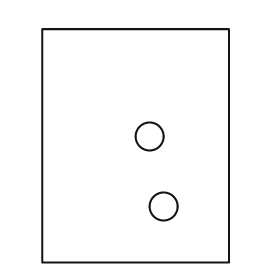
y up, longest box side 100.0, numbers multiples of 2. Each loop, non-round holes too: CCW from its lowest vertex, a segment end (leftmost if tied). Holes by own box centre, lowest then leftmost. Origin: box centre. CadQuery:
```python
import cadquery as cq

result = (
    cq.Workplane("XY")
    .moveTo(-40.0, -50.0)
    .lineTo(40.0, -50.0)
    .lineTo(40.0, 50.0)
    .lineTo(-40.0, 50.0)
    .close()
    .moveTo(12.0, -26.0)
    .circle(6.0)
    .moveTo(6.0, 4.0)
    .circle(6.0)
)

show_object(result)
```